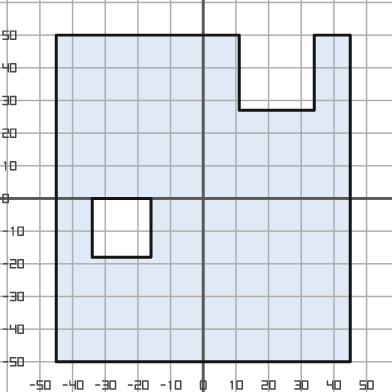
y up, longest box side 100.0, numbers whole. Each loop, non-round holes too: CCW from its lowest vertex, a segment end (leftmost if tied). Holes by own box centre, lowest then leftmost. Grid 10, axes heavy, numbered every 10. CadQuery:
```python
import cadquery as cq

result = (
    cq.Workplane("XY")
    .moveTo(-45.0, -50.0)
    .lineTo(45.0, -50.0)
    .lineTo(45.0, 50.0)
    .lineTo(34.0, 50.0)
    .lineTo(34.0, 27.0)
    .lineTo(11.0, 27.0)
    .lineTo(11.0, 50.0)
    .lineTo(-45.0, 50.0)
    .close()
    .moveTo(-34.0, -18.0)
    .lineTo(-16.0, -18.0)
    .lineTo(-16.0, 0.0)
    .lineTo(-34.0, 0.0)
    .close()
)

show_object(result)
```